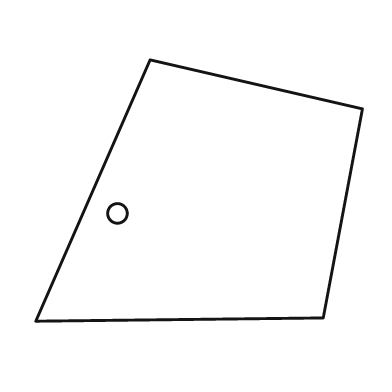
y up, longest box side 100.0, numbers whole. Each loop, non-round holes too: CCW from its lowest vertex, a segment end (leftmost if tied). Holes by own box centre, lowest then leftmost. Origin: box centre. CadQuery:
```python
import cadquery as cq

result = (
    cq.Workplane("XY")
    .moveTo(-50.0, -40.0)
    .lineTo(38.0, -39.0)
    .lineTo(50.0, 25.0)
    .lineTo(-15.0, 40.0)
    .close()
    .moveTo(-25.0, -7.0)
    .circle(3.0)
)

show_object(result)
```